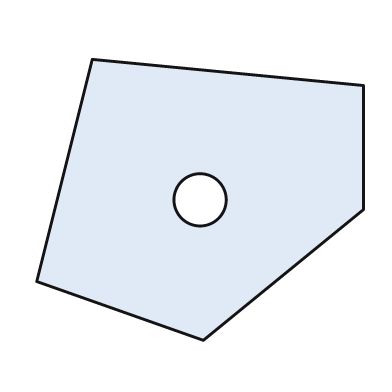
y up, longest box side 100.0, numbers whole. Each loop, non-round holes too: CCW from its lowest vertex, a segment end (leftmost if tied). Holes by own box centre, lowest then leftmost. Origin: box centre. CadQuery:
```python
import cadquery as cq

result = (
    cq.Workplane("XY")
    .moveTo(1.0, -43.0)
    .lineTo(50.0, -3.0)
    .lineTo(50.0, 35.0)
    .lineTo(-33.0, 43.0)
    .lineTo(-50.0, -25.0)
    .close()
    .moveTo(0.0, 0.0)
    .circle(8.0)
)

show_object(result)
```